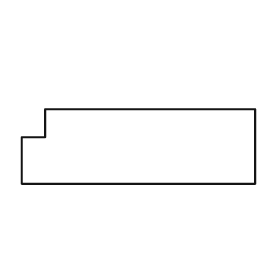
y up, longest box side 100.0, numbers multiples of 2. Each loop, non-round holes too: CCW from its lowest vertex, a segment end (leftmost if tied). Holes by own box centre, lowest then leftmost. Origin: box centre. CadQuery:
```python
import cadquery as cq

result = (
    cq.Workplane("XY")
    .moveTo(-50.0, -16.0)
    .lineTo(50.0, -16.0)
    .lineTo(50.0, 16.0)
    .lineTo(-40.0, 16.0)
    .lineTo(-40.0, 4.0)
    .lineTo(-50.0, 4.0)
    .close()
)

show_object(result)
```